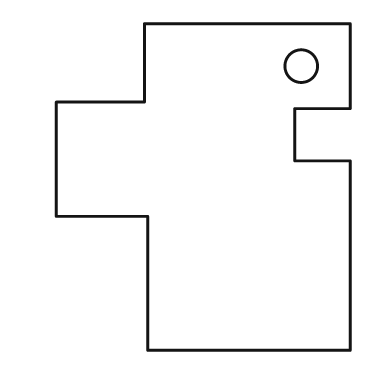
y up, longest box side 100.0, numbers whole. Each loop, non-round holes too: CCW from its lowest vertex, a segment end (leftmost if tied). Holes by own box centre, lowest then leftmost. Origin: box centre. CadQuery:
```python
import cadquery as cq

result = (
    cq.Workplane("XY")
    .moveTo(-17.0, -50.0)
    .lineTo(45.0, -50.0)
    .lineTo(45.0, 8.0)
    .lineTo(28.0, 8.0)
    .lineTo(28.0, 24.0)
    .lineTo(45.0, 24.0)
    .lineTo(45.0, 50.0)
    .lineTo(-18.0, 50.0)
    .lineTo(-18.0, 26.0)
    .lineTo(-45.0, 26.0)
    .lineTo(-45.0, -9.0)
    .lineTo(-17.0, -9.0)
    .close()
    .moveTo(30.0, 37.0)
    .circle(5.0)
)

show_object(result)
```